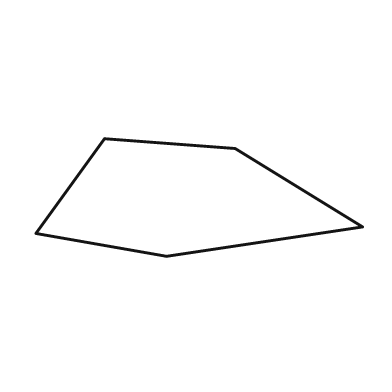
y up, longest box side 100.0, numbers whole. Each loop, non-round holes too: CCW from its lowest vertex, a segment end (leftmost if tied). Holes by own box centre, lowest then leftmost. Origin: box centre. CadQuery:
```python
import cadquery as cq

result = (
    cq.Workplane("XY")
    .moveTo(-10.0, -18.0)
    .lineTo(50.0, -9.0)
    .lineTo(11.0, 15.0)
    .lineTo(-29.0, 18.0)
    .lineTo(-50.0, -11.0)
    .close()
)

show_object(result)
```